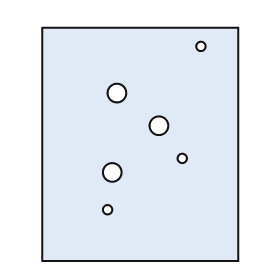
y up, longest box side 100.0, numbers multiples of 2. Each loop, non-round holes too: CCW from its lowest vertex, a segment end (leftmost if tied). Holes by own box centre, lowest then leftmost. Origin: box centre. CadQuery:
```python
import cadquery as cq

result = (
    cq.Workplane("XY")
    .moveTo(-42.0, -50.0)
    .lineTo(42.0, -50.0)
    .lineTo(42.0, 50.0)
    .lineTo(-42.0, 50.0)
    .close()
    .moveTo(-14.0, -28.0)
    .circle(2.0)
    .moveTo(-12.0, -12.0)
    .circle(4.0)
    .moveTo(18.0, -6.0)
    .circle(2.0)
    .moveTo(8.0, 8.0)
    .circle(4.0)
    .moveTo(-10.0, 22.0)
    .circle(4.0)
    .moveTo(26.0, 42.0)
    .circle(2.0)
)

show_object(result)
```